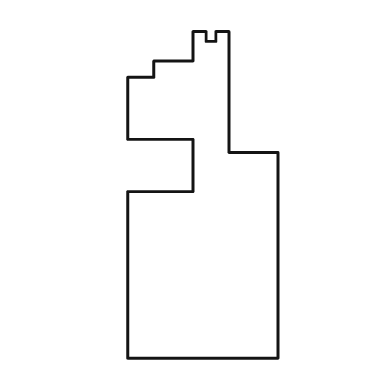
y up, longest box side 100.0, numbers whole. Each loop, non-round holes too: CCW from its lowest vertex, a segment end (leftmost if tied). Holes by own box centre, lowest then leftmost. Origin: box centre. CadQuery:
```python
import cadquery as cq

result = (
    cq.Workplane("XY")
    .moveTo(-23.0, -50.0)
    .lineTo(23.0, -50.0)
    .lineTo(23.0, 13.0)
    .lineTo(8.0, 13.0)
    .lineTo(8.0, 50.0)
    .lineTo(4.0, 50.0)
    .lineTo(4.0, 47.0)
    .lineTo(1.0, 47.0)
    .lineTo(1.0, 50.0)
    .lineTo(-3.0, 50.0)
    .lineTo(-3.0, 41.0)
    .lineTo(-15.0, 41.0)
    .lineTo(-15.0, 36.0)
    .lineTo(-23.0, 36.0)
    .lineTo(-23.0, 17.0)
    .lineTo(-3.0, 17.0)
    .lineTo(-3.0, 1.0)
    .lineTo(-23.0, 1.0)
    .close()
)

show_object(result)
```